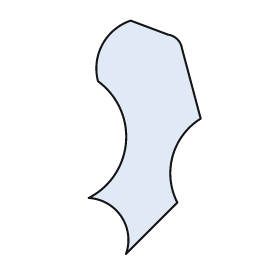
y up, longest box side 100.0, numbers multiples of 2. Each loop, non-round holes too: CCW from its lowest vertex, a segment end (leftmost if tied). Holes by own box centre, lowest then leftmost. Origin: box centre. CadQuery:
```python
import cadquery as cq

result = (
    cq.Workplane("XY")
    .moveTo(-8.0, -50.0)
    .lineTo(14.0, -28.0)
    .threePointArc((12.0, -8.0), (24.0, 8.0))
    .lineTo(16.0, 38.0)
    .threePointArc((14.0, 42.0), (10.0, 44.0))
    .lineTo(-6.0, 50.0)
    .threePointArc((-18.0, 40.0), (-20.0, 24.0))
    .threePointArc((-8.0, -2.0), (-24.0, -26.0))
    .threePointArc((-10.0, -34.0), (-8.0, -50.0))
    .close()
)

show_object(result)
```